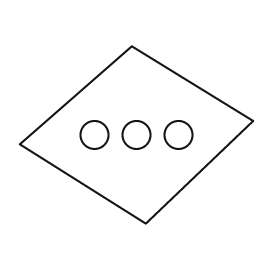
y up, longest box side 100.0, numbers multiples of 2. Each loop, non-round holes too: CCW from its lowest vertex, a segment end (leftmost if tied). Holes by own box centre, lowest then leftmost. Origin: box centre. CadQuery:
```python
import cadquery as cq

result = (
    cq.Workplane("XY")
    .moveTo(4.0, -38.0)
    .lineTo(50.0, 6.0)
    .lineTo(-2.0, 38.0)
    .lineTo(-50.0, -4.0)
    .close()
    .moveTo(-18.0, 0.0)
    .circle(6.0)
    .moveTo(0.0, 0.0)
    .circle(6.0)
    .moveTo(18.0, 0.0)
    .circle(6.0)
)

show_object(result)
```